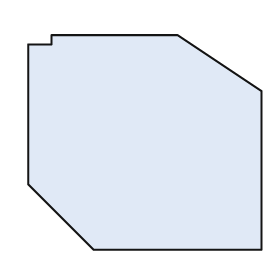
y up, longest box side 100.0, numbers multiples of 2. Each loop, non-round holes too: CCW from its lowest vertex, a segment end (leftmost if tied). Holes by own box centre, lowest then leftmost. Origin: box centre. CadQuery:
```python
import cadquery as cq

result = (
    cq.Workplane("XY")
    .moveTo(-22.0, -46.0)
    .lineTo(50.0, -46.0)
    .lineTo(50.0, 22.0)
    .lineTo(14.0, 46.0)
    .lineTo(-40.0, 46.0)
    .lineTo(-40.0, 42.0)
    .lineTo(-50.0, 42.0)
    .lineTo(-50.0, -18.0)
    .close()
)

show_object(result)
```